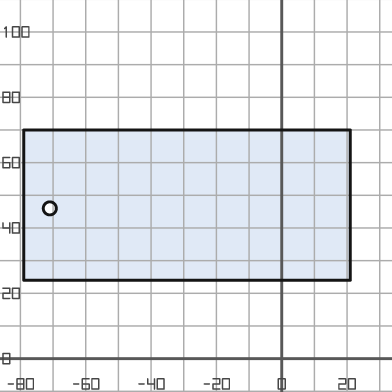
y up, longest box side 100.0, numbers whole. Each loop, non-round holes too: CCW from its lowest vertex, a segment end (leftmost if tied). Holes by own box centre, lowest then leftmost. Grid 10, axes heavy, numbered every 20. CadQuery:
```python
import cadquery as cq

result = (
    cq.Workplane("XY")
    .moveTo(-79.0, 24.0)
    .lineTo(21.0, 24.0)
    .lineTo(21.0, 70.0)
    .lineTo(-79.0, 70.0)
    .close()
    .moveTo(-71.0, 46.0)
    .circle(2.0)
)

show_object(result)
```